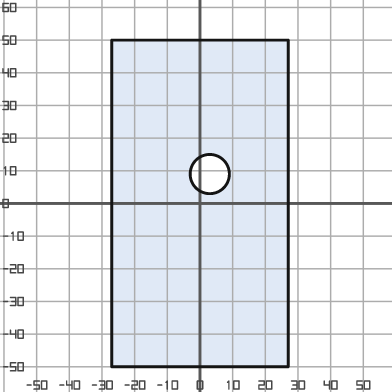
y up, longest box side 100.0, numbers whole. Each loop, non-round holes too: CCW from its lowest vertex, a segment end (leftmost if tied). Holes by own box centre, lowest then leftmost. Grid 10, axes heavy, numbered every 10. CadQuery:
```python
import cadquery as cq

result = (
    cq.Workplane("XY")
    .moveTo(-27.0, -50.0)
    .lineTo(27.0, -50.0)
    .lineTo(27.0, 50.0)
    .lineTo(-27.0, 50.0)
    .close()
    .moveTo(3.0, 9.0)
    .circle(6.0)
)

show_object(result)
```